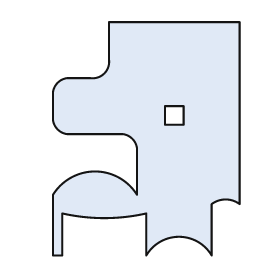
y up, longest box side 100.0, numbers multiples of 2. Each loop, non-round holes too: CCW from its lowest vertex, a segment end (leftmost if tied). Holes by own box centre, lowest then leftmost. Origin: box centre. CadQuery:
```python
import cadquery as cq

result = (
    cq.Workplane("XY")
    .moveTo(-40.0, -50.0)
    .lineTo(-36.0, -50.0)
    .lineTo(-36.0, -32.0)
    .threePointArc((-18.0, -34.0), (0.0, -32.0))
    .lineTo(0.0, -50.0)
    .threePointArc((14.0, -42.0), (28.0, -50.0))
    .lineTo(28.0, -28.0)
    .threePointArc((34.0, -26.0), (40.0, -28.0))
    .lineTo(40.0, 50.0)
    .lineTo(-16.0, 50.0)
    .lineTo(-16.0, 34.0)
    .threePointArc((-18.0, 28.0), (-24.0, 26.0))
    .lineTo(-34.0, 26.0)
    .threePointArc((-38.0, 24.0), (-40.0, 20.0))
    .lineTo(-40.0, 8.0)
    .threePointArc((-38.0, 4.0), (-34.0, 2.0))
    .lineTo(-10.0, 2.0)
    .threePointArc((-6.0, 0.0), (-4.0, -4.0))
    .lineTo(-4.0, -24.0)
    .threePointArc((-22.0, -14.0), (-40.0, -24.0))
    .close()
    .moveTo(8.0, 6.0)
    .lineTo(16.0, 6.0)
    .lineTo(16.0, 14.0)
    .lineTo(8.0, 14.0)
    .close()
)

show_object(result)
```